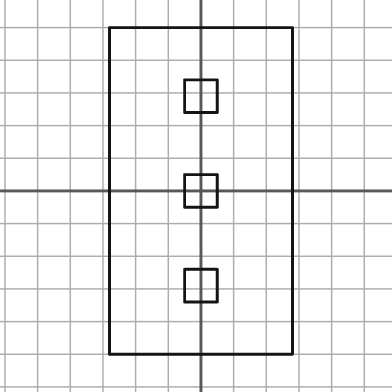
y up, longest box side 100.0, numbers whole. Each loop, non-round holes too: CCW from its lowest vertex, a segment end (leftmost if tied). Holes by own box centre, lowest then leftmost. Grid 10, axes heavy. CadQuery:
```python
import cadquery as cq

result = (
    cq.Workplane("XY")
    .moveTo(-28.0, -50.0)
    .lineTo(28.0, -50.0)
    .lineTo(28.0, 50.0)
    .lineTo(-28.0, 50.0)
    .close()
    .moveTo(-5.0, -34.0)
    .lineTo(5.0, -34.0)
    .lineTo(5.0, -24.0)
    .lineTo(-5.0, -24.0)
    .close()
    .moveTo(-5.0, -5.0)
    .lineTo(5.0, -5.0)
    .lineTo(5.0, 5.0)
    .lineTo(-5.0, 5.0)
    .close()
    .moveTo(-5.0, 24.0)
    .lineTo(5.0, 24.0)
    .lineTo(5.0, 34.0)
    .lineTo(-5.0, 34.0)
    .close()
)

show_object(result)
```